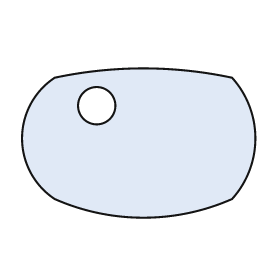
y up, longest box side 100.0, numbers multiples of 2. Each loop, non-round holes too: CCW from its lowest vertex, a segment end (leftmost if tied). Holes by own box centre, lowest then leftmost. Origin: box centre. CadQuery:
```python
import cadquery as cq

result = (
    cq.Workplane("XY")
    .moveTo(-36.0, -24.0)
    .threePointArc((2.0, -32.0), (40.0, -24.0))
    .threePointArc((50.0, 2.0), (40.0, 28.0))
    .threePointArc((2.0, 32.0), (-36.0, 28.0))
    .threePointArc((-50.0, 2.0), (-36.0, -24.0))
    .close()
    .moveTo(-18.0, 16.0)
    .circle(8.0)
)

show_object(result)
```